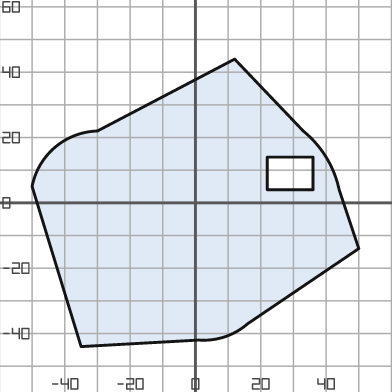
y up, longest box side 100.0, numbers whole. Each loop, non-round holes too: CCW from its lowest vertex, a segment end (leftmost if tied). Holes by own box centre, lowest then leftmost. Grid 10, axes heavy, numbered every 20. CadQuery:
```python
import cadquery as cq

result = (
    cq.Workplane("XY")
    .moveTo(-35.0, -44.0)
    .lineTo(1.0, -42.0)
    .threePointArc((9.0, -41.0), (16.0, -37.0))
    .lineTo(50.0, -14.0)
    .lineTo(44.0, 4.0)
    .threePointArc((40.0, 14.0), (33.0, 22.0))
    .lineTo(12.0, 44.0)
    .lineTo(-30.0, 22.0)
    .threePointArc((-43.0, 17.0), (-50.0, 5.0))
    .close()
    .moveTo(22.0, 4.0)
    .lineTo(36.0, 4.0)
    .lineTo(36.0, 14.0)
    .lineTo(22.0, 14.0)
    .close()
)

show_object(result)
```